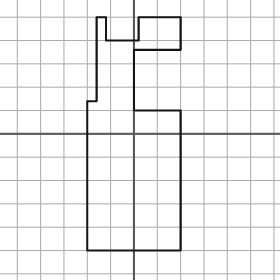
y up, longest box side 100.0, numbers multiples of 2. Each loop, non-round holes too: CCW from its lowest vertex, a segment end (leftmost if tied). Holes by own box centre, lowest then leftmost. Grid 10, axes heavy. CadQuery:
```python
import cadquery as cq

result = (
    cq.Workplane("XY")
    .moveTo(-20.0, -50.0)
    .lineTo(20.0, -50.0)
    .lineTo(20.0, 10.0)
    .lineTo(0.0, 10.0)
    .lineTo(0.0, 36.0)
    .lineTo(20.0, 36.0)
    .lineTo(20.0, 50.0)
    .lineTo(2.0, 50.0)
    .lineTo(2.0, 40.0)
    .lineTo(-12.0, 40.0)
    .lineTo(-12.0, 50.0)
    .lineTo(-16.0, 50.0)
    .lineTo(-16.0, 14.0)
    .lineTo(-20.0, 14.0)
    .close()
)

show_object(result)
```